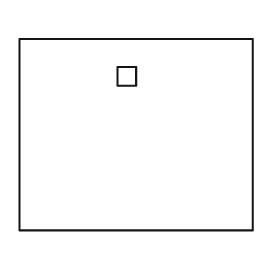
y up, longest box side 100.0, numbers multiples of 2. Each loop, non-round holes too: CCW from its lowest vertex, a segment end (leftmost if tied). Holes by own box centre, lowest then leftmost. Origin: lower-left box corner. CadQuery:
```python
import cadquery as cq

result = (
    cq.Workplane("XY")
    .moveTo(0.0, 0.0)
    .lineTo(100.0, 0.0)
    .lineTo(100.0, 82.0)
    .lineTo(0.0, 82.0)
    .close()
    .moveTo(42.0, 62.0)
    .lineTo(50.0, 62.0)
    .lineTo(50.0, 70.0)
    .lineTo(42.0, 70.0)
    .close()
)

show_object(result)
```